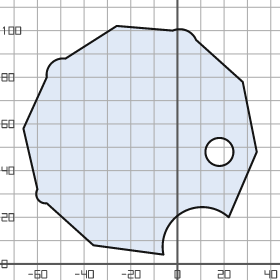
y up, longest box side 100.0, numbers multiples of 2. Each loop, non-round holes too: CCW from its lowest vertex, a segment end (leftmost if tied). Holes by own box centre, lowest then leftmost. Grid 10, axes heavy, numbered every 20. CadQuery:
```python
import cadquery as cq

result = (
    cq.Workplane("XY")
    .moveTo(-6.0, 4.0)
    .threePointArc((2.0, 22.0), (22.0, 20.0))
    .lineTo(34.0, 48.0)
    .lineTo(28.0, 78.0)
    .lineTo(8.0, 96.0)
    .threePointArc((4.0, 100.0), (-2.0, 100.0))
    .lineTo(-26.0, 102.0)
    .lineTo(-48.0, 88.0)
    .threePointArc((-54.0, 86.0), (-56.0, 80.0))
    .lineTo(-66.0, 58.0)
    .lineTo(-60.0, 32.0)
    .threePointArc((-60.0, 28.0), (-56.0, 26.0))
    .lineTo(-36.0, 8.0)
    .close()
    .moveTo(18.0, 48.0)
    .circle(6.0)
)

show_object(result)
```